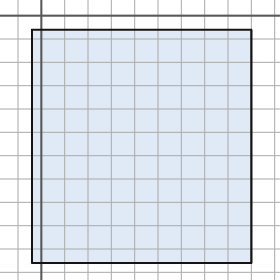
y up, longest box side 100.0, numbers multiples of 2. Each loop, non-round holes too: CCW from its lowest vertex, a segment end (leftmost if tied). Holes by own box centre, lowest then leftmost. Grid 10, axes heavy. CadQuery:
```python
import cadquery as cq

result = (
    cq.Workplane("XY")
    .moveTo(-4.0, -106.0)
    .lineTo(90.0, -106.0)
    .lineTo(90.0, -6.0)
    .lineTo(-4.0, -6.0)
    .close()
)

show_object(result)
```